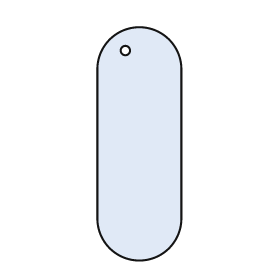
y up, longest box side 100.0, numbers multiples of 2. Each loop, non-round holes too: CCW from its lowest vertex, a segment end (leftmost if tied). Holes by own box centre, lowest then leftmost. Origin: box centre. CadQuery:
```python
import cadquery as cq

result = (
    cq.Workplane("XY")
    .moveTo(-18.0, -32.0)
    .threePointArc((0.0, -50.0), (18.0, -32.0))
    .lineTo(18.0, 32.0)
    .threePointArc((0.0, 50.0), (-18.0, 32.0))
    .close()
    .moveTo(-6.0, 40.0)
    .circle(2.0)
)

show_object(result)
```